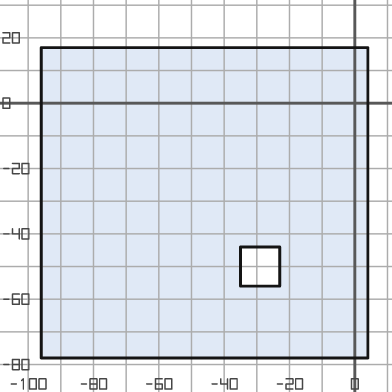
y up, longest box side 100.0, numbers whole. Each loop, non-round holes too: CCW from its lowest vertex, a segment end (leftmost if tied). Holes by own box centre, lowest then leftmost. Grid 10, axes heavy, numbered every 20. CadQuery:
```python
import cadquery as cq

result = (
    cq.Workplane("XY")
    .moveTo(-96.0, -78.0)
    .lineTo(4.0, -78.0)
    .lineTo(4.0, 17.0)
    .lineTo(-96.0, 17.0)
    .close()
    .moveTo(-35.0, -56.0)
    .lineTo(-23.0, -56.0)
    .lineTo(-23.0, -44.0)
    .lineTo(-35.0, -44.0)
    .close()
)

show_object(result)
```